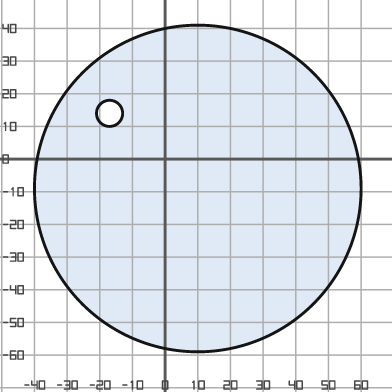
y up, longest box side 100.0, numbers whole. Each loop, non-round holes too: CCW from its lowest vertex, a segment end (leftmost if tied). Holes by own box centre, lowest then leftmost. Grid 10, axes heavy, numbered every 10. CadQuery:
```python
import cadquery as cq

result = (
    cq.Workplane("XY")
    .moveTo(10.0, -9.0)
    .circle(50.0)
    .moveTo(-17.0, 14.0)
    .circle(4.0)
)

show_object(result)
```